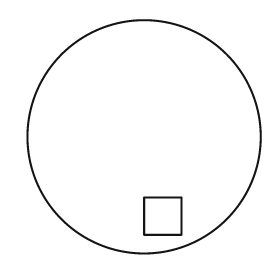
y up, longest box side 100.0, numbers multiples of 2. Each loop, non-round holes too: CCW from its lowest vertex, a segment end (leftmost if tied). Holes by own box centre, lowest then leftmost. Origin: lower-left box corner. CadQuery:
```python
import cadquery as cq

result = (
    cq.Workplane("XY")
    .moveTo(50.0, 50.0)
    .circle(50.0)
    .moveTo(50.0, 8.0)
    .lineTo(66.0, 8.0)
    .lineTo(66.0, 24.0)
    .lineTo(50.0, 24.0)
    .close()
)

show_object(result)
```